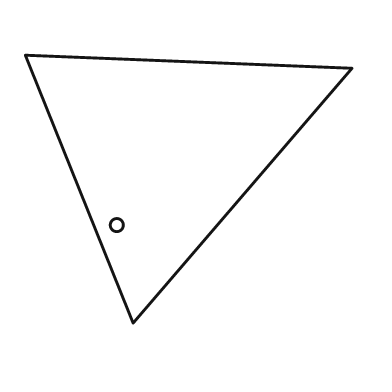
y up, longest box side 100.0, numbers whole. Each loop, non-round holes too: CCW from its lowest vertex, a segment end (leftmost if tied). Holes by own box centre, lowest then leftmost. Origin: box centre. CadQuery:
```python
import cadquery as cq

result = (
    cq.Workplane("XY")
    .moveTo(-17.0, -41.0)
    .lineTo(50.0, 37.0)
    .lineTo(-50.0, 41.0)
    .close()
    .moveTo(-22.0, -11.0)
    .circle(2.0)
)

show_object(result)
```